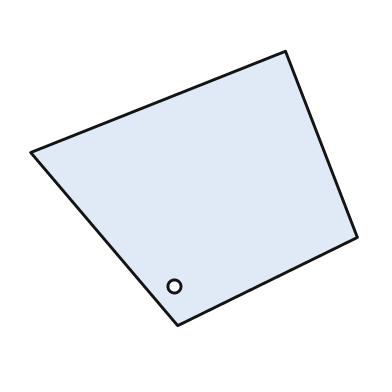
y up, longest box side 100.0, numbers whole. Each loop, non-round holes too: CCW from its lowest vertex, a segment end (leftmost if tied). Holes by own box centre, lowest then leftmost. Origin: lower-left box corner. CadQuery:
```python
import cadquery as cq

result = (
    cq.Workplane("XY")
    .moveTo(45.0, 0.0)
    .lineTo(100.0, 27.0)
    .lineTo(78.0, 84.0)
    .lineTo(0.0, 53.0)
    .close()
    .moveTo(44.0, 12.0)
    .circle(2.0)
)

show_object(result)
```